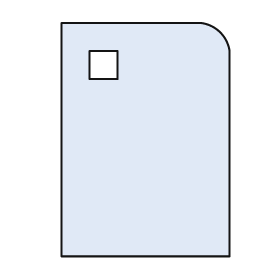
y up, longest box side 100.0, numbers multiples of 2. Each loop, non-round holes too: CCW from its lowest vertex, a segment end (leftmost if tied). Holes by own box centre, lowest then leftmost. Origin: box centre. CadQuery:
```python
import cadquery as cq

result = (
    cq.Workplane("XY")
    .moveTo(-36.0, -50.0)
    .lineTo(36.0, -50.0)
    .lineTo(36.0, 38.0)
    .threePointArc((32.0, 46.0), (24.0, 50.0))
    .lineTo(-36.0, 50.0)
    .close()
    .moveTo(-24.0, 26.0)
    .lineTo(-12.0, 26.0)
    .lineTo(-12.0, 38.0)
    .lineTo(-24.0, 38.0)
    .close()
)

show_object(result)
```